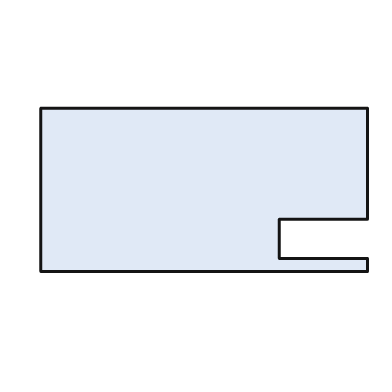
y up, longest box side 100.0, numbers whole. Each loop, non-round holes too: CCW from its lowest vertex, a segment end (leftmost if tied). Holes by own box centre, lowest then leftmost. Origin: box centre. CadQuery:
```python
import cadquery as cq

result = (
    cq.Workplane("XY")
    .moveTo(-50.0, -25.0)
    .lineTo(50.0, -25.0)
    .lineTo(50.0, -21.0)
    .lineTo(23.0, -21.0)
    .lineTo(23.0, -9.0)
    .lineTo(50.0, -9.0)
    .lineTo(50.0, 25.0)
    .lineTo(-50.0, 25.0)
    .close()
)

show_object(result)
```